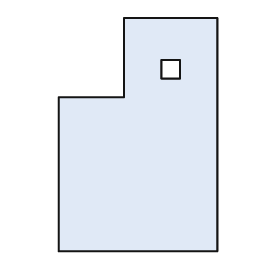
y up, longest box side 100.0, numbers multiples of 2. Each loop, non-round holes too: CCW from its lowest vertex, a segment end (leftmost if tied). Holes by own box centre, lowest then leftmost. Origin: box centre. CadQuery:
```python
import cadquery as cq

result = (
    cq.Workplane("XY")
    .moveTo(-34.0, -50.0)
    .lineTo(34.0, -50.0)
    .lineTo(34.0, 50.0)
    .lineTo(-6.0, 50.0)
    .lineTo(-6.0, 16.0)
    .lineTo(-34.0, 16.0)
    .close()
    .moveTo(10.0, 24.0)
    .lineTo(18.0, 24.0)
    .lineTo(18.0, 32.0)
    .lineTo(10.0, 32.0)
    .close()
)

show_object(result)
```